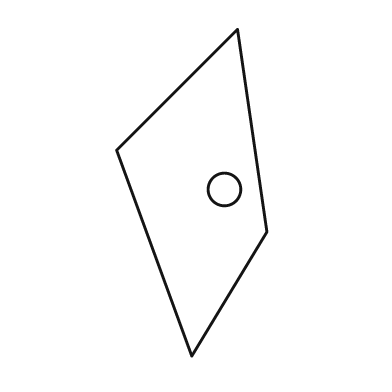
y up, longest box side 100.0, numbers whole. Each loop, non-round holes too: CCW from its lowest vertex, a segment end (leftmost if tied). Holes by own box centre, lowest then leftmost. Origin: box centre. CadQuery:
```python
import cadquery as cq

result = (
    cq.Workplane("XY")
    .moveTo(0.0, -50.0)
    .lineTo(23.0, -12.0)
    .lineTo(14.0, 50.0)
    .lineTo(-23.0, 13.0)
    .close()
    .moveTo(10.0, 1.0)
    .circle(5.0)
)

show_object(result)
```